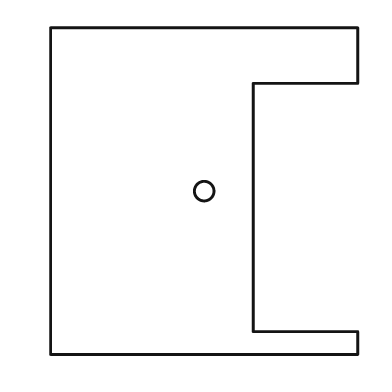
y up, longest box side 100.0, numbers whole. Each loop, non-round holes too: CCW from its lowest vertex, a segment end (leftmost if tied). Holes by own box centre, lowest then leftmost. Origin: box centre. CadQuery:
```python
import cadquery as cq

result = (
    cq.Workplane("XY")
    .moveTo(-47.0, -50.0)
    .lineTo(47.0, -50.0)
    .lineTo(47.0, -43.0)
    .lineTo(15.0, -43.0)
    .lineTo(15.0, 33.0)
    .lineTo(47.0, 33.0)
    .lineTo(47.0, 50.0)
    .lineTo(-47.0, 50.0)
    .close()
    .moveTo(0.0, 0.0)
    .circle(3.0)
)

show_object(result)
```